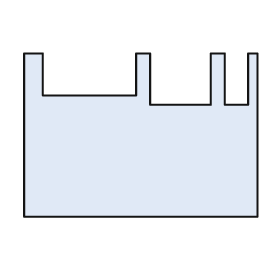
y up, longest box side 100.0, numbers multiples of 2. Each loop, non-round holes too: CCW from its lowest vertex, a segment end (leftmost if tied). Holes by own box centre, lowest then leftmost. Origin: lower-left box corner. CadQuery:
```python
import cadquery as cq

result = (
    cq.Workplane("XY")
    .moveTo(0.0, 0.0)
    .lineTo(100.0, 0.0)
    .lineTo(100.0, 70.0)
    .lineTo(96.0, 70.0)
    .lineTo(96.0, 48.0)
    .lineTo(86.0, 48.0)
    .lineTo(86.0, 70.0)
    .lineTo(80.0, 70.0)
    .lineTo(80.0, 48.0)
    .lineTo(54.0, 48.0)
    .lineTo(54.0, 70.0)
    .lineTo(48.0, 70.0)
    .lineTo(48.0, 52.0)
    .lineTo(8.0, 52.0)
    .lineTo(8.0, 70.0)
    .lineTo(0.0, 70.0)
    .close()
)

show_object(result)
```